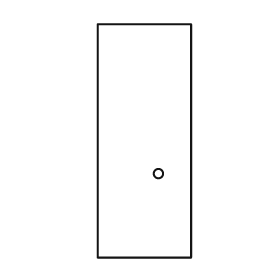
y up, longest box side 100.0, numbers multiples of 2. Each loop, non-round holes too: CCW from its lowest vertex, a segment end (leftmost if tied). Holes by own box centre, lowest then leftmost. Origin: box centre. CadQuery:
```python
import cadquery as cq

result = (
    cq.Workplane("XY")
    .moveTo(-20.0, -50.0)
    .lineTo(20.0, -50.0)
    .lineTo(20.0, 50.0)
    .lineTo(-20.0, 50.0)
    .close()
    .moveTo(6.0, -14.0)
    .circle(2.0)
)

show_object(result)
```